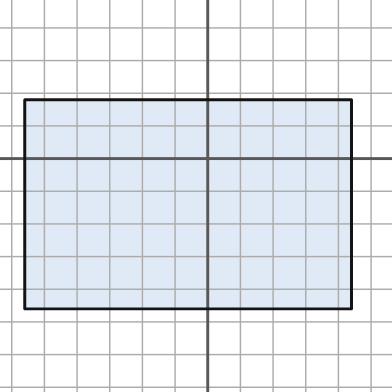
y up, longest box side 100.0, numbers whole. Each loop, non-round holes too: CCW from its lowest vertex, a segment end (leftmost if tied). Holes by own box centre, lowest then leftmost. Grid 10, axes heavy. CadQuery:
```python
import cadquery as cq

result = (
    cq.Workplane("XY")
    .moveTo(-56.0, -46.0)
    .lineTo(44.0, -46.0)
    .lineTo(44.0, 18.0)
    .lineTo(-56.0, 18.0)
    .close()
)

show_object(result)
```